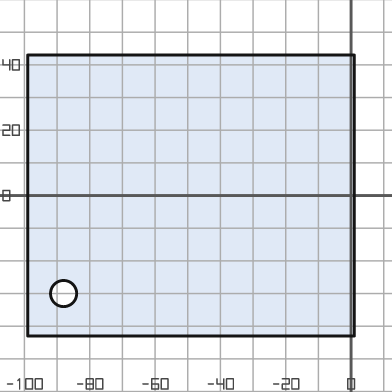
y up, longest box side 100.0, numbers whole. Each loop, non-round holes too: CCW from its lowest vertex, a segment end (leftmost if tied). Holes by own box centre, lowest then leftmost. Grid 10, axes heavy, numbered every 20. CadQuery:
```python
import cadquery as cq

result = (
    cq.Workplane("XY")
    .moveTo(-99.0, -43.0)
    .lineTo(1.0, -43.0)
    .lineTo(1.0, 43.0)
    .lineTo(-99.0, 43.0)
    .close()
    .moveTo(-88.0, -30.0)
    .circle(4.0)
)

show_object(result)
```